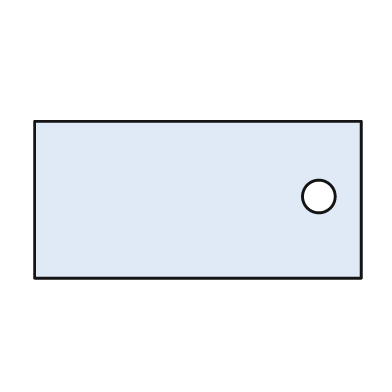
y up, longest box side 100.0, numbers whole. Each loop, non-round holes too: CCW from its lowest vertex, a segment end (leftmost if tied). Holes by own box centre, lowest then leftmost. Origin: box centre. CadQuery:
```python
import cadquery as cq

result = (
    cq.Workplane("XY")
    .moveTo(-50.0, -24.0)
    .lineTo(50.0, -24.0)
    .lineTo(50.0, 24.0)
    .lineTo(-50.0, 24.0)
    .close()
    .moveTo(37.0, 1.0)
    .circle(5.0)
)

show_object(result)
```